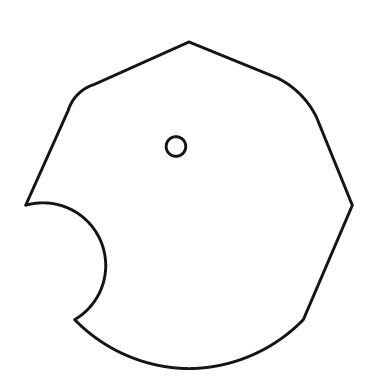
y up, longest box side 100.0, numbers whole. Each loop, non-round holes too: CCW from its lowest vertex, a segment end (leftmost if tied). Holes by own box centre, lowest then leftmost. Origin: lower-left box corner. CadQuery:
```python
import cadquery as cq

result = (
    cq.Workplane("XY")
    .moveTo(50.0, 0.0)
    .threePointArc((69.0, 4.0), (85.0, 15.0))
    .lineTo(100.0, 50.0)
    .lineTo(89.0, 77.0)
    .threePointArc((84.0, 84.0), (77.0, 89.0))
    .lineTo(50.0, 100.0)
    .lineTo(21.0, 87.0)
    .threePointArc((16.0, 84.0), (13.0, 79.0))
    .lineTo(0.0, 50.0)
    .threePointArc((23.0, 39.0), (15.0, 15.0))
    .threePointArc((31.0, 4.0), (50.0, 0.0))
    .close()
    .moveTo(46.0, 68.0)
    .circle(3.0)
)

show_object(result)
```